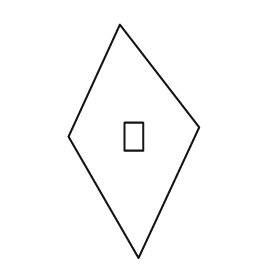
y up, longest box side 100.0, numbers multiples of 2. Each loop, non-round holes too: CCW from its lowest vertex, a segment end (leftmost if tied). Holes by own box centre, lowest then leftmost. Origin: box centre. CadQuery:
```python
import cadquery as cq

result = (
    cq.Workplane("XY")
    .moveTo(2.0, -50.0)
    .lineTo(28.0, 6.0)
    .lineTo(-6.0, 50.0)
    .lineTo(-28.0, 2.0)
    .close()
    .moveTo(-4.0, -4.0)
    .lineTo(4.0, -4.0)
    .lineTo(4.0, 8.0)
    .lineTo(-4.0, 8.0)
    .close()
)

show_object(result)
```